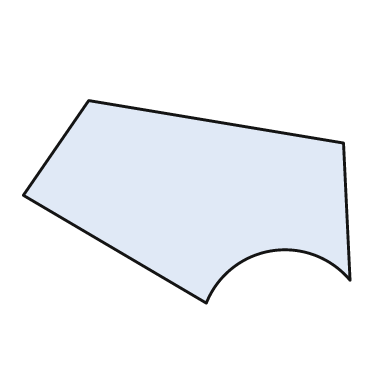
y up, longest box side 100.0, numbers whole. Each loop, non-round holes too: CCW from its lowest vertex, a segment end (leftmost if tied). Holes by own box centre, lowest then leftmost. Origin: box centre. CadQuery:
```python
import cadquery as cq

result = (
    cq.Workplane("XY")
    .moveTo(6.0, -31.0)
    .threePointArc((26.0, -15.0), (50.0, -24.0))
    .lineTo(48.0, 18.0)
    .lineTo(-30.0, 31.0)
    .lineTo(-50.0, 2.0)
    .close()
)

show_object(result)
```